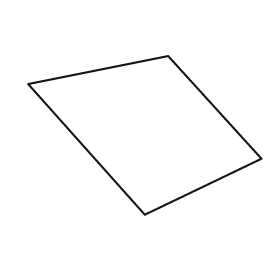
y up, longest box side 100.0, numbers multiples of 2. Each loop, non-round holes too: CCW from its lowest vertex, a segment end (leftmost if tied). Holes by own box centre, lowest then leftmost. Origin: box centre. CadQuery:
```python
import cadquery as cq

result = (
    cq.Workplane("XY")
    .moveTo(0.0, -34.0)
    .lineTo(50.0, -10.0)
    .lineTo(10.0, 34.0)
    .lineTo(-50.0, 22.0)
    .close()
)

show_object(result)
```